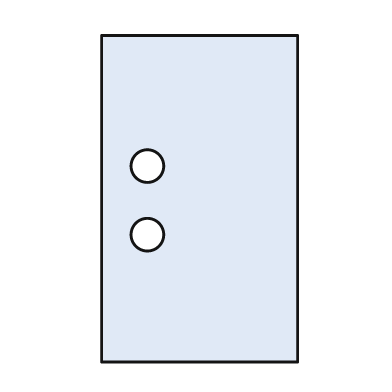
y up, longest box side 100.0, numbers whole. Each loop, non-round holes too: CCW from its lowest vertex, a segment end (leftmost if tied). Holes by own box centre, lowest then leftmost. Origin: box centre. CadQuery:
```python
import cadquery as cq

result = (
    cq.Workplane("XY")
    .moveTo(-30.0, -50.0)
    .lineTo(30.0, -50.0)
    .lineTo(30.0, 50.0)
    .lineTo(-30.0, 50.0)
    .close()
    .moveTo(-16.0, -11.0)
    .circle(5.0)
    .moveTo(-16.0, 10.0)
    .circle(5.0)
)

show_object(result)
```